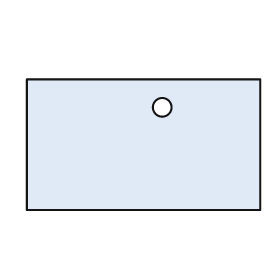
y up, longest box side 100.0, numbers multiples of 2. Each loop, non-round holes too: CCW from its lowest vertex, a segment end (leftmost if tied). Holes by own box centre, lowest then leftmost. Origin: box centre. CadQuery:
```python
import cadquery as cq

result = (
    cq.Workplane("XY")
    .moveTo(-50.0, -28.0)
    .lineTo(50.0, -28.0)
    .lineTo(50.0, 28.0)
    .lineTo(-50.0, 28.0)
    .close()
    .moveTo(8.0, 16.0)
    .circle(4.0)
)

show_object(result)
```